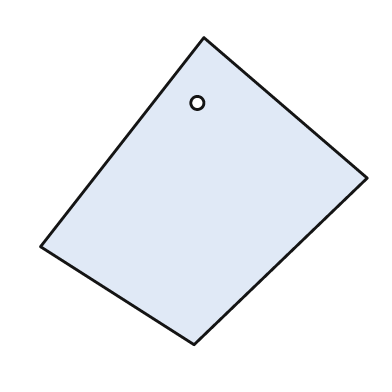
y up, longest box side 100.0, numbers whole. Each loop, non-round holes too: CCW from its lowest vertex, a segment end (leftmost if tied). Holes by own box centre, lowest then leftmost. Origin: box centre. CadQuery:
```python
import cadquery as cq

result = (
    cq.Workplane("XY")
    .moveTo(-3.0, -47.0)
    .lineTo(50.0, 4.0)
    .lineTo(0.0, 47.0)
    .lineTo(-50.0, -17.0)
    .close()
    .moveTo(-2.0, 27.0)
    .circle(2.0)
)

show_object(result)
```